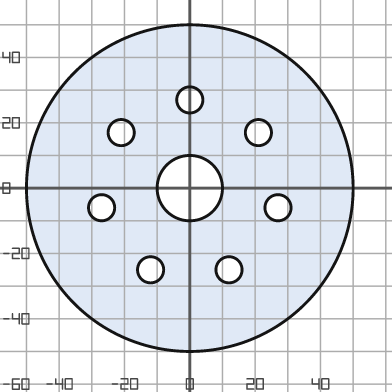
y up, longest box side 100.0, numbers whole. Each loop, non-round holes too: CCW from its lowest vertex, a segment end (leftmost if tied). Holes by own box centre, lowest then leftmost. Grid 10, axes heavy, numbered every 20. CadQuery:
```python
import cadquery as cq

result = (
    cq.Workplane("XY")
    .moveTo(0.0, 0.0)
    .circle(50.0)
    .moveTo(-12.0, -25.0)
    .circle(4.0)
    .moveTo(12.0, -25.0)
    .circle(4.0)
    .moveTo(-27.0, -6.0)
    .circle(4.0)
    .moveTo(27.0, -6.0)
    .circle(4.0)
    .moveTo(0.0, 0.0)
    .circle(10.0)
    .moveTo(-21.0, 17.0)
    .circle(4.0)
    .moveTo(21.0, 17.0)
    .circle(4.0)
    .moveTo(0.0, 27.0)
    .circle(4.0)
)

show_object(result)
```